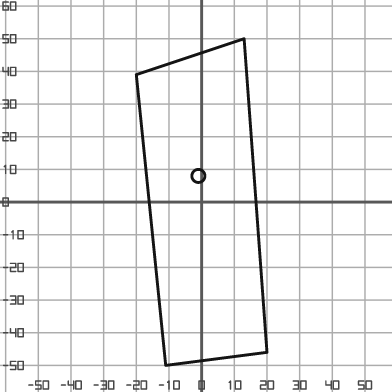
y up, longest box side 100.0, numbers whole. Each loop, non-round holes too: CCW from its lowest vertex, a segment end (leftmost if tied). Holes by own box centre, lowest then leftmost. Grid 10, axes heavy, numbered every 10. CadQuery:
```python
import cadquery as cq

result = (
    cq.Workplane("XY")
    .moveTo(-11.0, -50.0)
    .lineTo(20.0, -46.0)
    .lineTo(13.0, 50.0)
    .lineTo(-20.0, 39.0)
    .close()
    .moveTo(-1.0, 8.0)
    .circle(2.0)
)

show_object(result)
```